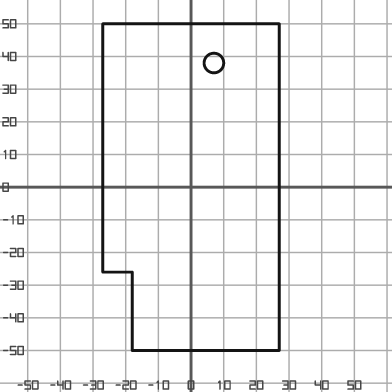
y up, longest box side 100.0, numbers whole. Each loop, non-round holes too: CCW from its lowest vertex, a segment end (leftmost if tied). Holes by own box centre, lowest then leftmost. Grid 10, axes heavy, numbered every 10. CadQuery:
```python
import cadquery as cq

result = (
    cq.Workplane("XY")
    .moveTo(-18.0, -50.0)
    .lineTo(27.0, -50.0)
    .lineTo(27.0, 50.0)
    .lineTo(-27.0, 50.0)
    .lineTo(-27.0, -26.0)
    .lineTo(-18.0, -26.0)
    .close()
    .moveTo(7.0, 38.0)
    .circle(3.0)
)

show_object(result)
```